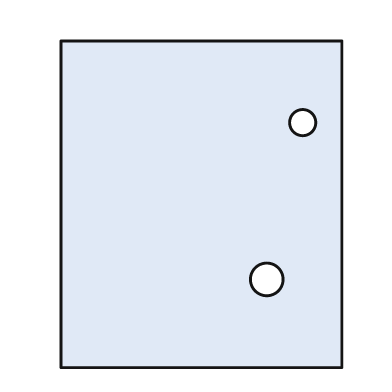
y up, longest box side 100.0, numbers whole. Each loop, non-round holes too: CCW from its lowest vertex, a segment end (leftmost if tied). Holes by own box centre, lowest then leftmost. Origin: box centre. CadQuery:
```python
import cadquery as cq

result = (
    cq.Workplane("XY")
    .moveTo(-43.0, -50.0)
    .lineTo(43.0, -50.0)
    .lineTo(43.0, 50.0)
    .lineTo(-43.0, 50.0)
    .close()
    .moveTo(20.0, -23.0)
    .circle(5.0)
    .moveTo(31.0, 25.0)
    .circle(4.0)
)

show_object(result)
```